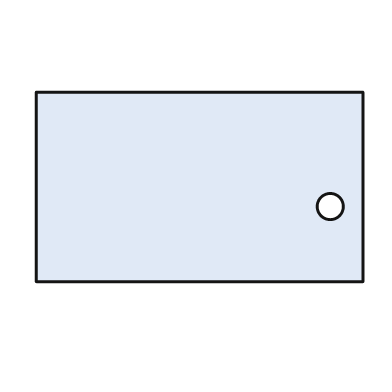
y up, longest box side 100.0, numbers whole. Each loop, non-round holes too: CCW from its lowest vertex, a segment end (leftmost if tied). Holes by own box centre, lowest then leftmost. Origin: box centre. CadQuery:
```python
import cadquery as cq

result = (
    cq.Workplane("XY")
    .moveTo(-50.0, -29.0)
    .lineTo(50.0, -29.0)
    .lineTo(50.0, 29.0)
    .lineTo(-50.0, 29.0)
    .close()
    .moveTo(40.0, -6.0)
    .circle(4.0)
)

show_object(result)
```